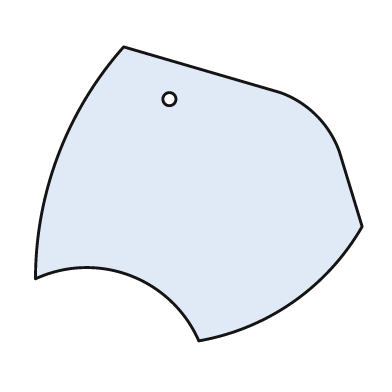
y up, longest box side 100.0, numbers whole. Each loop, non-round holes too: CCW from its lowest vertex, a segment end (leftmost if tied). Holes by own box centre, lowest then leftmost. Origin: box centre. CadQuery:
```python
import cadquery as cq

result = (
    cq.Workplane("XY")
    .moveTo(0.0, -45.0)
    .threePointArc((29.0, -33.0), (50.0, -10.0))
    .lineTo(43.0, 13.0)
    .threePointArc((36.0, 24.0), (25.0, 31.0))
    .lineTo(-23.0, 45.0)
    .threePointArc((-43.0, 12.0), (-50.0, -26.0))
    .threePointArc((-21.0, -25.0), (0.0, -45.0))
    .close()
    .moveTo(-9.0, 29.0)
    .circle(2.0)
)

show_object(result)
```